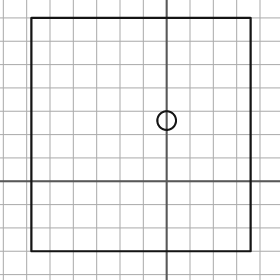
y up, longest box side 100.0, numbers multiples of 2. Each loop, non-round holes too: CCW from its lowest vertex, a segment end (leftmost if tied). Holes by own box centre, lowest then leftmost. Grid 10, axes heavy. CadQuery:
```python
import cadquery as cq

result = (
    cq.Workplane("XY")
    .moveTo(-58.0, -30.0)
    .lineTo(36.0, -30.0)
    .lineTo(36.0, 70.0)
    .lineTo(-58.0, 70.0)
    .close()
    .moveTo(0.0, 26.0)
    .circle(4.0)
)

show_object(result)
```